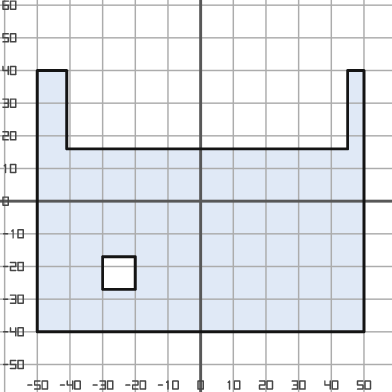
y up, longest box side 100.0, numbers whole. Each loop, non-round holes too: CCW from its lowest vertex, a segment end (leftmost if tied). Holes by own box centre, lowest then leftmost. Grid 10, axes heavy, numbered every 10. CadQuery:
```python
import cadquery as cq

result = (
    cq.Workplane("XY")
    .moveTo(-50.0, -40.0)
    .lineTo(50.0, -40.0)
    .lineTo(50.0, 40.0)
    .lineTo(45.0, 40.0)
    .lineTo(45.0, 16.0)
    .lineTo(-41.0, 16.0)
    .lineTo(-41.0, 40.0)
    .lineTo(-50.0, 40.0)
    .close()
    .moveTo(-30.0, -27.0)
    .lineTo(-20.0, -27.0)
    .lineTo(-20.0, -17.0)
    .lineTo(-30.0, -17.0)
    .close()
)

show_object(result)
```